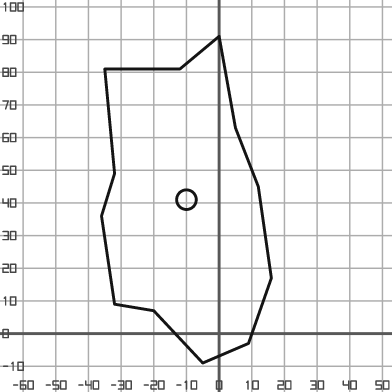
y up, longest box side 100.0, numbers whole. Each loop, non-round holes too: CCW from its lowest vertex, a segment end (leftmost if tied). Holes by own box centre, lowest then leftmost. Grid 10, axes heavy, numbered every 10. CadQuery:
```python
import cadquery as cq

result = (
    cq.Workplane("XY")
    .moveTo(-5.0, -9.0)
    .lineTo(9.0, -3.0)
    .lineTo(16.0, 17.0)
    .lineTo(12.0, 45.0)
    .lineTo(5.0, 63.0)
    .lineTo(0.0, 91.0)
    .lineTo(-12.0, 81.0)
    .lineTo(-35.0, 81.0)
    .lineTo(-32.0, 49.0)
    .lineTo(-36.0, 36.0)
    .lineTo(-32.0, 9.0)
    .lineTo(-20.0, 7.0)
    .close()
    .moveTo(-10.0, 41.0)
    .circle(3.0)
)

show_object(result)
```